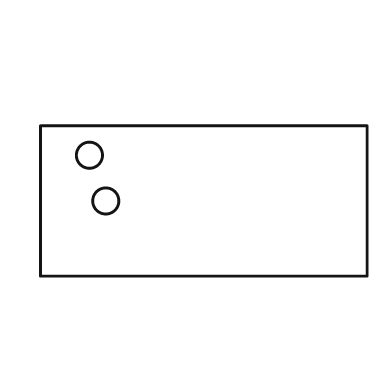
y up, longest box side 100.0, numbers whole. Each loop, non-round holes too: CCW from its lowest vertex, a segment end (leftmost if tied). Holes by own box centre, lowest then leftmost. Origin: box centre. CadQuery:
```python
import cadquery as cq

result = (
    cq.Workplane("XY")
    .moveTo(-50.0, -23.0)
    .lineTo(50.0, -23.0)
    .lineTo(50.0, 23.0)
    .lineTo(-50.0, 23.0)
    .close()
    .moveTo(-30.0, 0.0)
    .circle(4.0)
    .moveTo(-35.0, 14.0)
    .circle(4.0)
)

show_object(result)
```